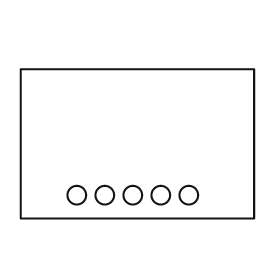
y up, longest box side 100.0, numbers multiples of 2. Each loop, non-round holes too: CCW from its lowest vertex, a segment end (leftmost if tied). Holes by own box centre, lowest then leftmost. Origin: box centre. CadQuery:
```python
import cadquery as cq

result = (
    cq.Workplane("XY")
    .moveTo(-50.0, -32.0)
    .lineTo(50.0, -32.0)
    .lineTo(50.0, 32.0)
    .lineTo(-50.0, 32.0)
    .close()
    .moveTo(-26.0, -22.0)
    .circle(4.0)
    .moveTo(-14.0, -22.0)
    .circle(4.0)
    .moveTo(-2.0, -22.0)
    .circle(4.0)
    .moveTo(10.0, -22.0)
    .circle(4.0)
    .moveTo(22.0, -22.0)
    .circle(4.0)
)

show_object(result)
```